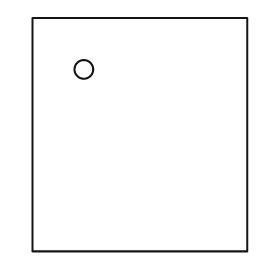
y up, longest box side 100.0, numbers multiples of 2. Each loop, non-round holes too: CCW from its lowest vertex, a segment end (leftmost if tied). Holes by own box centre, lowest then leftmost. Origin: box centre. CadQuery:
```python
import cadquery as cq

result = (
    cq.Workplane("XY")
    .moveTo(-46.0, -50.0)
    .lineTo(46.0, -50.0)
    .lineTo(46.0, 50.0)
    .lineTo(-46.0, 50.0)
    .close()
    .moveTo(-24.0, 28.0)
    .circle(4.0)
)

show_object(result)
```